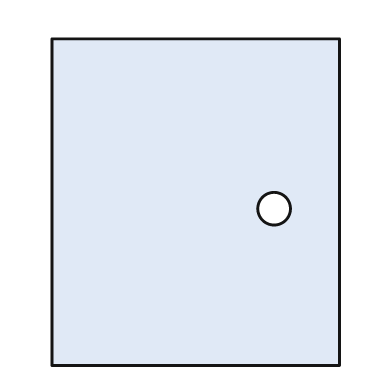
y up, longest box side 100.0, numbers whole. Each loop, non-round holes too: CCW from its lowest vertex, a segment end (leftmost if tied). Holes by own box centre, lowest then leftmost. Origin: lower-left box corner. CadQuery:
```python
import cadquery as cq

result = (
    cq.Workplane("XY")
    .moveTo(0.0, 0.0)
    .lineTo(88.0, 0.0)
    .lineTo(88.0, 100.0)
    .lineTo(0.0, 100.0)
    .close()
    .moveTo(68.0, 48.0)
    .circle(5.0)
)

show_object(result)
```